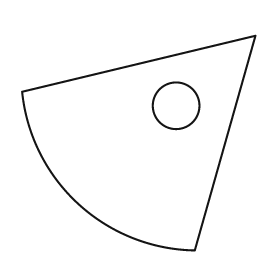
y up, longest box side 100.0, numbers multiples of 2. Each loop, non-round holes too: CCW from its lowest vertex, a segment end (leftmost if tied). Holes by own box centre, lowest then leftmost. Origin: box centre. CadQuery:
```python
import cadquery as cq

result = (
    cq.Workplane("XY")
    .moveTo(24.0, -46.0)
    .lineTo(50.0, 46.0)
    .lineTo(-50.0, 22.0)
    .threePointArc((-26.0, -26.0), (24.0, -46.0))
    .close()
    .moveTo(16.0, 16.0)
    .circle(10.0)
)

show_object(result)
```